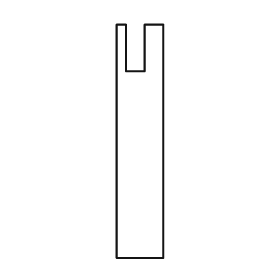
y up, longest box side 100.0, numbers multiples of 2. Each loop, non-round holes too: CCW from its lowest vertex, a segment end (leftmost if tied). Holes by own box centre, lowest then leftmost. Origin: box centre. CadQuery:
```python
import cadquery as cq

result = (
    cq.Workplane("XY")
    .moveTo(-10.0, -50.0)
    .lineTo(10.0, -50.0)
    .lineTo(10.0, 50.0)
    .lineTo(2.0, 50.0)
    .lineTo(2.0, 30.0)
    .lineTo(-6.0, 30.0)
    .lineTo(-6.0, 50.0)
    .lineTo(-10.0, 50.0)
    .close()
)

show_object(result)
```